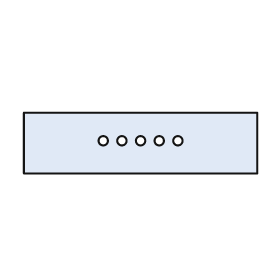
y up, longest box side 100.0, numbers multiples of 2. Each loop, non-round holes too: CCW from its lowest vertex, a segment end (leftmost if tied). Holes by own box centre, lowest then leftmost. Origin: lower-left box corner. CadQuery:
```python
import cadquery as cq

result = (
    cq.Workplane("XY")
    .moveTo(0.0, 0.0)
    .lineTo(100.0, 0.0)
    .lineTo(100.0, 26.0)
    .lineTo(0.0, 26.0)
    .close()
    .moveTo(34.0, 14.0)
    .circle(2.0)
    .moveTo(42.0, 14.0)
    .circle(2.0)
    .moveTo(50.0, 14.0)
    .circle(2.0)
    .moveTo(58.0, 14.0)
    .circle(2.0)
    .moveTo(66.0, 14.0)
    .circle(2.0)
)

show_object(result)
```